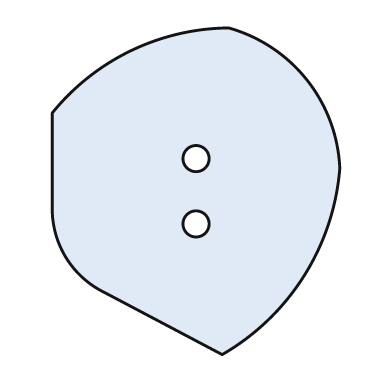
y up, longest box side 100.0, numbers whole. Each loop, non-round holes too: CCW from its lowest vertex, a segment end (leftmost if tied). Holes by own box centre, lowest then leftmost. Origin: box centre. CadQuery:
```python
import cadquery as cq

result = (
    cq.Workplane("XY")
    .moveTo(8.0, -50.0)
    .threePointArc((33.0, -26.0), (44.0, 7.0))
    .threePointArc((34.0, 34.0), (10.0, 50.0))
    .threePointArc((-20.0, 43.0), (-44.0, 24.0))
    .lineTo(-44.0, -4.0)
    .threePointArc((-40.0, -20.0), (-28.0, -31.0))
    .close()
    .moveTo(0.0, -10.0)
    .circle(4.0)
    .moveTo(0.0, 10.0)
    .circle(4.0)
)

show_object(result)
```